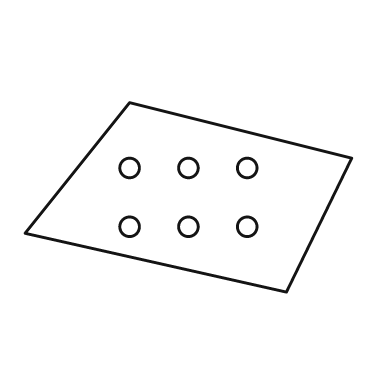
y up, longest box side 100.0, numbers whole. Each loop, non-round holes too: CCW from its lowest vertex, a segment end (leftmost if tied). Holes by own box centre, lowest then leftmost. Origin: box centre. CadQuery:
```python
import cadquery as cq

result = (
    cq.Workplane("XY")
    .moveTo(30.0, -29.0)
    .lineTo(50.0, 12.0)
    .lineTo(-18.0, 29.0)
    .lineTo(-50.0, -11.0)
    .close()
    .moveTo(-18.0, -9.0)
    .circle(3.0)
    .moveTo(0.0, -9.0)
    .circle(3.0)
    .moveTo(18.0, -9.0)
    .circle(3.0)
    .moveTo(-18.0, 9.0)
    .circle(3.0)
    .moveTo(0.0, 9.0)
    .circle(3.0)
    .moveTo(18.0, 9.0)
    .circle(3.0)
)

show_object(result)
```